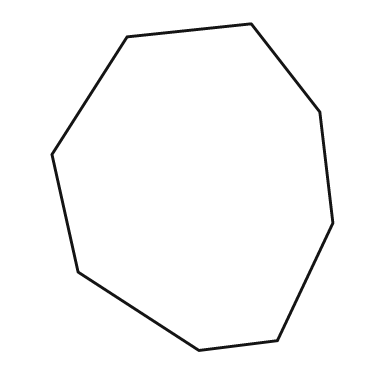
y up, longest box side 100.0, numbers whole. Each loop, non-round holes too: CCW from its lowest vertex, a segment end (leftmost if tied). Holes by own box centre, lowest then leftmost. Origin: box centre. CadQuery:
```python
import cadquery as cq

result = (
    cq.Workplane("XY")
    .moveTo(2.0, -50.0)
    .lineTo(26.0, -47.0)
    .lineTo(43.0, -11.0)
    .lineTo(39.0, 23.0)
    .lineTo(18.0, 50.0)
    .lineTo(-20.0, 46.0)
    .lineTo(-43.0, 10.0)
    .lineTo(-35.0, -26.0)
    .close()
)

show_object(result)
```